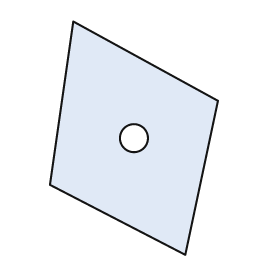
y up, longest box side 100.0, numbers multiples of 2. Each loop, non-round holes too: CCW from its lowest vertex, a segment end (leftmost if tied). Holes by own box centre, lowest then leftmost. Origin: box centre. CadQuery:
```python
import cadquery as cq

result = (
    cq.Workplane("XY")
    .moveTo(22.0, -50.0)
    .lineTo(36.0, 16.0)
    .lineTo(-26.0, 50.0)
    .lineTo(-36.0, -20.0)
    .close()
    .moveTo(0.0, 0.0)
    .circle(6.0)
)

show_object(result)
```